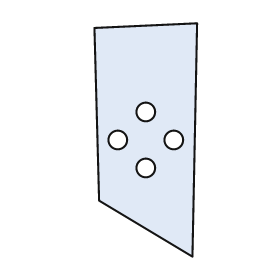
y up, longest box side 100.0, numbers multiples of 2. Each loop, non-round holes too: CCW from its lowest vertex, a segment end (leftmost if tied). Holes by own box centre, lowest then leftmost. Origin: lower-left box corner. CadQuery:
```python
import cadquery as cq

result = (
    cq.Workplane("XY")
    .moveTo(42.0, 0.0)
    .lineTo(44.0, 100.0)
    .lineTo(0.0, 98.0)
    .lineTo(2.0, 24.0)
    .close()
    .moveTo(22.0, 38.0)
    .circle(4.0)
    .moveTo(10.0, 50.0)
    .circle(4.0)
    .moveTo(34.0, 50.0)
    .circle(4.0)
    .moveTo(22.0, 62.0)
    .circle(4.0)
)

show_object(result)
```